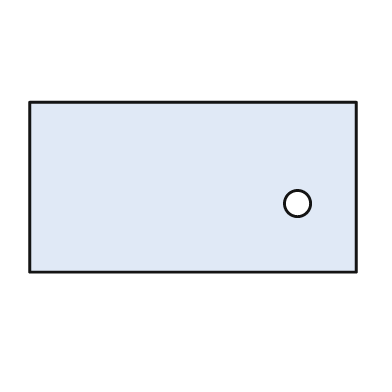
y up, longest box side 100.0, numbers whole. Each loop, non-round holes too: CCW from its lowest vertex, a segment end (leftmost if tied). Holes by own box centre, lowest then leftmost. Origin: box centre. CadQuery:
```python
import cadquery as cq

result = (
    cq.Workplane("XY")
    .moveTo(-50.0, -26.0)
    .lineTo(50.0, -26.0)
    .lineTo(50.0, 26.0)
    .lineTo(-50.0, 26.0)
    .close()
    .moveTo(32.0, -5.0)
    .circle(4.0)
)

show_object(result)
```